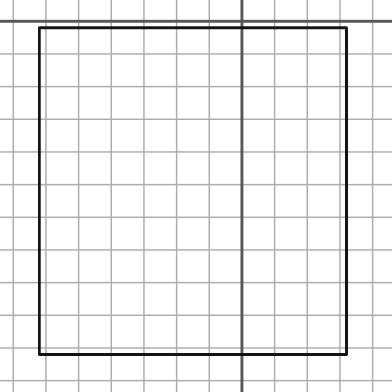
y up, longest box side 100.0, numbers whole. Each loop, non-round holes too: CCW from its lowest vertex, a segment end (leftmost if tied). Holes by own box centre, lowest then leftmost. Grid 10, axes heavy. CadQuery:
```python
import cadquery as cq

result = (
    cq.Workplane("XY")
    .moveTo(-62.0, -102.0)
    .lineTo(32.0, -102.0)
    .lineTo(32.0, -2.0)
    .lineTo(-62.0, -2.0)
    .close()
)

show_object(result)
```